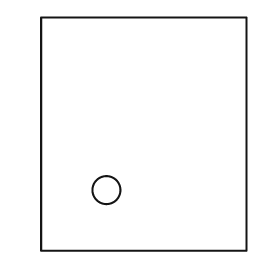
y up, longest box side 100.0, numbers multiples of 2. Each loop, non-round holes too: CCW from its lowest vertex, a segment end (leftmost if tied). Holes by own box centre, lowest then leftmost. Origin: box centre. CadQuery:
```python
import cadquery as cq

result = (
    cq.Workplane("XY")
    .moveTo(-44.0, -50.0)
    .lineTo(44.0, -50.0)
    .lineTo(44.0, 50.0)
    .lineTo(-44.0, 50.0)
    .close()
    .moveTo(-16.0, -24.0)
    .circle(6.0)
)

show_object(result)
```